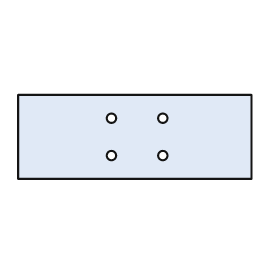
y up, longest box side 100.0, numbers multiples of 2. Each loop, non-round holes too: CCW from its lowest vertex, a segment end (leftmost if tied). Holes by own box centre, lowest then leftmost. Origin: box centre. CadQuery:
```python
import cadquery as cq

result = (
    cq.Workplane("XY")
    .moveTo(-50.0, -18.0)
    .lineTo(50.0, -18.0)
    .lineTo(50.0, 18.0)
    .lineTo(-50.0, 18.0)
    .close()
    .moveTo(-10.0, -8.0)
    .circle(2.0)
    .moveTo(12.0, -8.0)
    .circle(2.0)
    .moveTo(-10.0, 8.0)
    .circle(2.0)
    .moveTo(12.0, 8.0)
    .circle(2.0)
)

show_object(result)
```